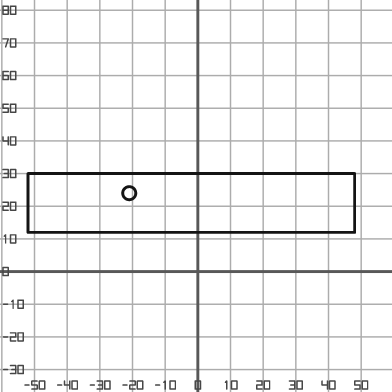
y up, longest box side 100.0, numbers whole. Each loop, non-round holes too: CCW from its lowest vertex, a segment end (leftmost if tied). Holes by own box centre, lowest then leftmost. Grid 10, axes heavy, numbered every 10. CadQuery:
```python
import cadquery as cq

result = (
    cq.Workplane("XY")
    .moveTo(-52.0, 12.0)
    .lineTo(48.0, 12.0)
    .lineTo(48.0, 30.0)
    .lineTo(-52.0, 30.0)
    .close()
    .moveTo(-21.0, 24.0)
    .circle(2.0)
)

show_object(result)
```